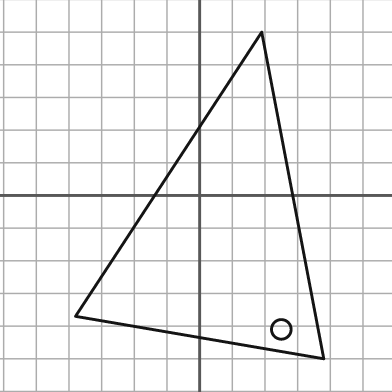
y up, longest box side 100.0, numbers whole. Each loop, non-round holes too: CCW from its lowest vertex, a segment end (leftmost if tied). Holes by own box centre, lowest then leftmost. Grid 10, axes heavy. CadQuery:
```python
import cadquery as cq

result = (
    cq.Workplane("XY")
    .moveTo(38.0, -50.0)
    .lineTo(19.0, 50.0)
    .lineTo(-38.0, -37.0)
    .close()
    .moveTo(25.0, -41.0)
    .circle(3.0)
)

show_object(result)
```